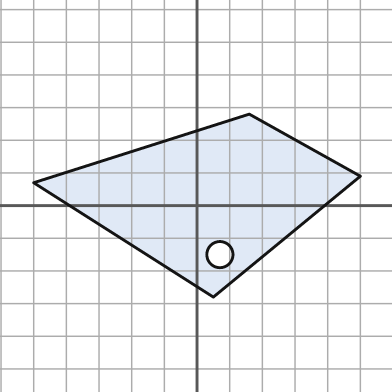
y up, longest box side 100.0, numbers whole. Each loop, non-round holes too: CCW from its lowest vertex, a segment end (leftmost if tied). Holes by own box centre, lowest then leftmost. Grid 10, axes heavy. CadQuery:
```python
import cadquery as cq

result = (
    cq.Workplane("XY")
    .moveTo(5.0, -28.0)
    .lineTo(50.0, 9.0)
    .lineTo(16.0, 28.0)
    .lineTo(-50.0, 7.0)
    .close()
    .moveTo(7.0, -15.0)
    .circle(4.0)
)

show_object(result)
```